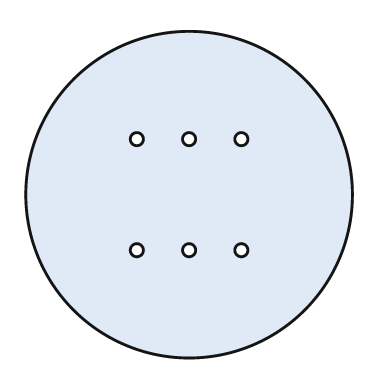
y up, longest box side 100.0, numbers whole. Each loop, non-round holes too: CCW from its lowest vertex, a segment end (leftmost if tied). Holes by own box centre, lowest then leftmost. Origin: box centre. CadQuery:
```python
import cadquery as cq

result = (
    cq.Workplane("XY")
    .moveTo(0.0, 0.0)
    .circle(50.0)
    .moveTo(-16.0, -17.0)
    .circle(2.0)
    .moveTo(0.0, -17.0)
    .circle(2.0)
    .moveTo(16.0, -17.0)
    .circle(2.0)
    .moveTo(-16.0, 17.0)
    .circle(2.0)
    .moveTo(0.0, 17.0)
    .circle(2.0)
    .moveTo(16.0, 17.0)
    .circle(2.0)
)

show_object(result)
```